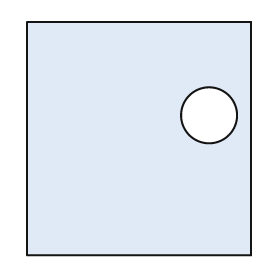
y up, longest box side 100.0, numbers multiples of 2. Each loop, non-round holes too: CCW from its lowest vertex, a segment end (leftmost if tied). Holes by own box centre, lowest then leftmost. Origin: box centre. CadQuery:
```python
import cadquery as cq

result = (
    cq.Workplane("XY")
    .moveTo(-48.0, -50.0)
    .lineTo(48.0, -50.0)
    .lineTo(48.0, 50.0)
    .lineTo(-48.0, 50.0)
    .close()
    .moveTo(30.0, 10.0)
    .circle(12.0)
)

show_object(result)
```